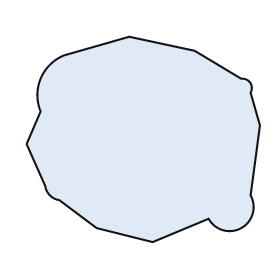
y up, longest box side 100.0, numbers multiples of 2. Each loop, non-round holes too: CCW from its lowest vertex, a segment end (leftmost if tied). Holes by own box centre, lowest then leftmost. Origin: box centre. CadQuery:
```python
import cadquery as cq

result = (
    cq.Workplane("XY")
    .moveTo(4.0, -44.0)
    .lineTo(28.0, -34.0)
    .threePointArc((42.0, -38.0), (46.0, -24.0))
    .lineTo(50.0, 6.0)
    .lineTo(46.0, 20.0)
    .threePointArc((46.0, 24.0), (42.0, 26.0))
    .lineTo(22.0, 38.0)
    .lineTo(-6.0, 44.0)
    .lineTo(-34.0, 36.0)
    .threePointArc((-44.0, 26.0), (-44.0, 12.0))
    .lineTo(-50.0, -2.0)
    .lineTo(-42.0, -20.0)
    .threePointArc((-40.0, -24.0), (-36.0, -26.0))
    .lineTo(-20.0, -38.0)
    .close()
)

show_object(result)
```